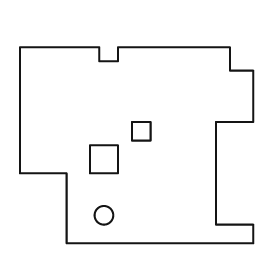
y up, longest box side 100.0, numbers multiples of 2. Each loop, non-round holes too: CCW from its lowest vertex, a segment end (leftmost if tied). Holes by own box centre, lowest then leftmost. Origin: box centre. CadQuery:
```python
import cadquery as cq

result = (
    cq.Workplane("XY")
    .moveTo(-30.0, -42.0)
    .lineTo(50.0, -42.0)
    .lineTo(50.0, -34.0)
    .lineTo(34.0, -34.0)
    .lineTo(34.0, 10.0)
    .lineTo(50.0, 10.0)
    .lineTo(50.0, 32.0)
    .lineTo(40.0, 32.0)
    .lineTo(40.0, 42.0)
    .lineTo(-8.0, 42.0)
    .lineTo(-8.0, 36.0)
    .lineTo(-16.0, 36.0)
    .lineTo(-16.0, 42.0)
    .lineTo(-50.0, 42.0)
    .lineTo(-50.0, -12.0)
    .lineTo(-30.0, -12.0)
    .close()
    .moveTo(-14.0, -30.0)
    .circle(4.0)
    .moveTo(-20.0, -12.0)
    .lineTo(-8.0, -12.0)
    .lineTo(-8.0, 0.0)
    .lineTo(-20.0, 0.0)
    .close()
    .moveTo(-2.0, 2.0)
    .lineTo(6.0, 2.0)
    .lineTo(6.0, 10.0)
    .lineTo(-2.0, 10.0)
    .close()
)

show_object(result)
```